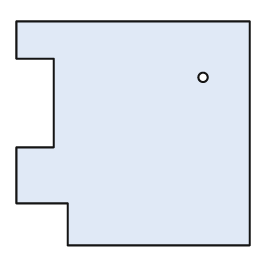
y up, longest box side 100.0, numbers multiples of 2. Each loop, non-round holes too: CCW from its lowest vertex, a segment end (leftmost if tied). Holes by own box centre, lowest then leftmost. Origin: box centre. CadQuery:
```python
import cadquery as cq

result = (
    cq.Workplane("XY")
    .moveTo(-28.0, -48.0)
    .lineTo(50.0, -48.0)
    .lineTo(50.0, 48.0)
    .lineTo(-50.0, 48.0)
    .lineTo(-50.0, 32.0)
    .lineTo(-34.0, 32.0)
    .lineTo(-34.0, -6.0)
    .lineTo(-50.0, -6.0)
    .lineTo(-50.0, -30.0)
    .lineTo(-28.0, -30.0)
    .close()
    .moveTo(30.0, 24.0)
    .circle(2.0)
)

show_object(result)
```